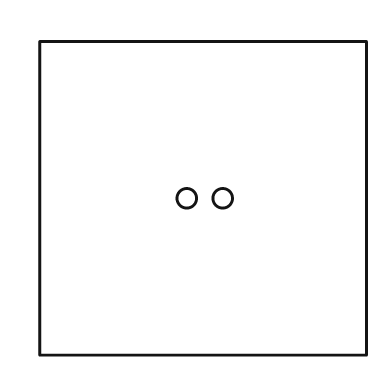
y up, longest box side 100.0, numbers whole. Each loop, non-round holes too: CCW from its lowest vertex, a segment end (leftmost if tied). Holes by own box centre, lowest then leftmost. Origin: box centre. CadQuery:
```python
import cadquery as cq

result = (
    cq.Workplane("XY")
    .moveTo(-50.0, -48.0)
    .lineTo(50.0, -48.0)
    .lineTo(50.0, 48.0)
    .lineTo(-50.0, 48.0)
    .close()
    .moveTo(-5.0, 0.0)
    .circle(3.0)
    .moveTo(6.0, 0.0)
    .circle(3.0)
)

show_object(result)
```